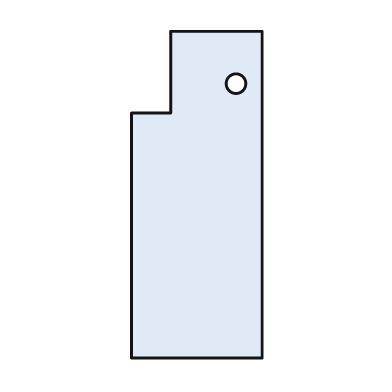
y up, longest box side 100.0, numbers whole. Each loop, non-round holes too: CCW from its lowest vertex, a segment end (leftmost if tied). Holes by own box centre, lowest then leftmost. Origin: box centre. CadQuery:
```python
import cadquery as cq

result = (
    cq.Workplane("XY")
    .moveTo(-20.0, -50.0)
    .lineTo(20.0, -50.0)
    .lineTo(20.0, 50.0)
    .lineTo(-8.0, 50.0)
    .lineTo(-8.0, 25.0)
    .lineTo(-20.0, 25.0)
    .close()
    .moveTo(12.0, 34.0)
    .circle(3.0)
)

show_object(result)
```